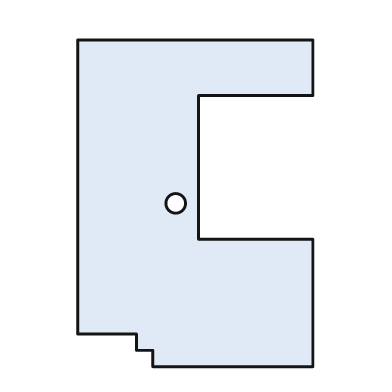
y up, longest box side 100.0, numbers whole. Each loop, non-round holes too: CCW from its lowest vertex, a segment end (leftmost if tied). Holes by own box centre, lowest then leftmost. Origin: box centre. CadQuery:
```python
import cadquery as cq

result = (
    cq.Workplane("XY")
    .moveTo(-13.0, -50.0)
    .lineTo(36.0, -50.0)
    .lineTo(36.0, -11.0)
    .lineTo(1.0, -11.0)
    .lineTo(1.0, 33.0)
    .lineTo(36.0, 33.0)
    .lineTo(36.0, 50.0)
    .lineTo(-36.0, 50.0)
    .lineTo(-36.0, -40.0)
    .lineTo(-18.0, -40.0)
    .lineTo(-18.0, -45.0)
    .lineTo(-13.0, -45.0)
    .close()
    .moveTo(-6.0, 0.0)
    .circle(3.0)
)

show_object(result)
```